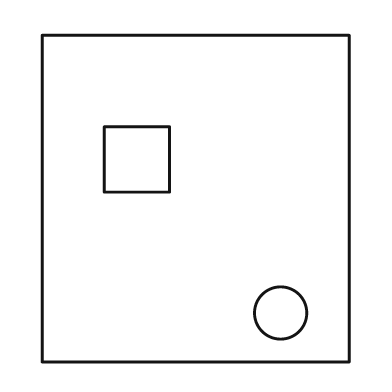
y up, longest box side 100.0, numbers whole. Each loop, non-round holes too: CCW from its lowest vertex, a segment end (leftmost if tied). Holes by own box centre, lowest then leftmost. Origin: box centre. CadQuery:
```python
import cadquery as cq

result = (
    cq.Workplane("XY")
    .moveTo(-47.0, -50.0)
    .lineTo(47.0, -50.0)
    .lineTo(47.0, 50.0)
    .lineTo(-47.0, 50.0)
    .close()
    .moveTo(26.0, -35.0)
    .circle(8.0)
    .moveTo(-28.0, 2.0)
    .lineTo(-8.0, 2.0)
    .lineTo(-8.0, 22.0)
    .lineTo(-28.0, 22.0)
    .close()
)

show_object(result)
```